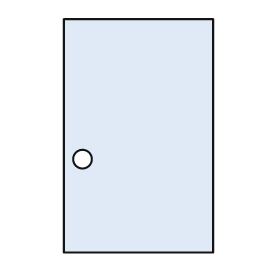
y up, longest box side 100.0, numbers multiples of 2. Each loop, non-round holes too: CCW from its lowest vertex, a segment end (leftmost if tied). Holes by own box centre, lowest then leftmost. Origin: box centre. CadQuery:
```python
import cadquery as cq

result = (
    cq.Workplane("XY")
    .moveTo(-32.0, -50.0)
    .lineTo(32.0, -50.0)
    .lineTo(32.0, 50.0)
    .lineTo(-32.0, 50.0)
    .close()
    .moveTo(-24.0, -10.0)
    .circle(4.0)
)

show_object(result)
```